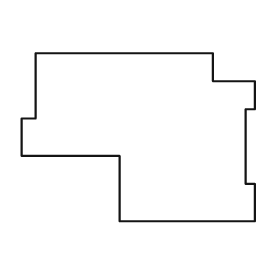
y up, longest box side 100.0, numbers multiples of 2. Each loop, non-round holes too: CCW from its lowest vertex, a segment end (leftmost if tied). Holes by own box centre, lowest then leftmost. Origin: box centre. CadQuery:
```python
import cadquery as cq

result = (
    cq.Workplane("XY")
    .moveTo(-8.0, -36.0)
    .lineTo(50.0, -36.0)
    .lineTo(50.0, -20.0)
    .lineTo(46.0, -20.0)
    .lineTo(46.0, 12.0)
    .lineTo(50.0, 12.0)
    .lineTo(50.0, 24.0)
    .lineTo(32.0, 24.0)
    .lineTo(32.0, 36.0)
    .lineTo(-44.0, 36.0)
    .lineTo(-44.0, 8.0)
    .lineTo(-50.0, 8.0)
    .lineTo(-50.0, -8.0)
    .lineTo(-8.0, -8.0)
    .close()
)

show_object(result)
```